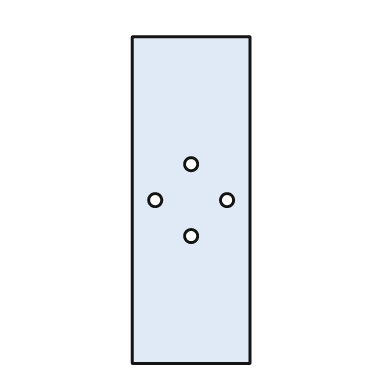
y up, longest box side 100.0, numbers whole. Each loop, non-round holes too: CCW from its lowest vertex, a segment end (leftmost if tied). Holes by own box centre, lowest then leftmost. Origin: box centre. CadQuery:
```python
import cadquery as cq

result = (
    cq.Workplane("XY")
    .moveTo(-18.0, -50.0)
    .lineTo(18.0, -50.0)
    .lineTo(18.0, 50.0)
    .lineTo(-18.0, 50.0)
    .close()
    .moveTo(0.0, -11.0)
    .circle(2.0)
    .moveTo(-11.0, 0.0)
    .circle(2.0)
    .moveTo(11.0, 0.0)
    .circle(2.0)
    .moveTo(0.0, 11.0)
    .circle(2.0)
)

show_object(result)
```